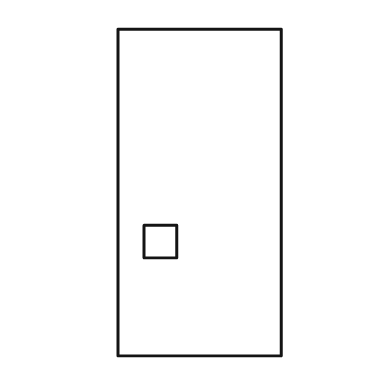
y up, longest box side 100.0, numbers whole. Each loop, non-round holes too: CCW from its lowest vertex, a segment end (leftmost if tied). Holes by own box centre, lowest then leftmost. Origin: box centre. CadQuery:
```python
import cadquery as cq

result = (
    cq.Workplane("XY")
    .moveTo(-25.0, -50.0)
    .lineTo(25.0, -50.0)
    .lineTo(25.0, 50.0)
    .lineTo(-25.0, 50.0)
    .close()
    .moveTo(-17.0, -20.0)
    .lineTo(-7.0, -20.0)
    .lineTo(-7.0, -10.0)
    .lineTo(-17.0, -10.0)
    .close()
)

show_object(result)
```